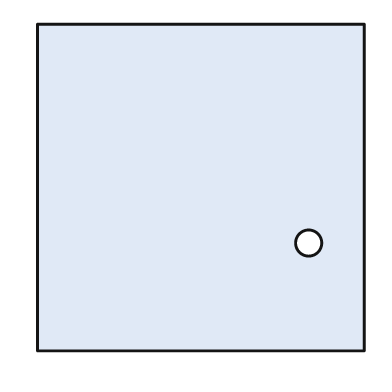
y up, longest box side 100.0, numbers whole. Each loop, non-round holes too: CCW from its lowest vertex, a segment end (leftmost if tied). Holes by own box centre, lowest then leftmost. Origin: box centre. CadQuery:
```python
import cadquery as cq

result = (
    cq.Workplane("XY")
    .moveTo(-50.0, -50.0)
    .lineTo(50.0, -50.0)
    .lineTo(50.0, 50.0)
    .lineTo(-50.0, 50.0)
    .close()
    .moveTo(33.0, -17.0)
    .circle(4.0)
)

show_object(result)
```